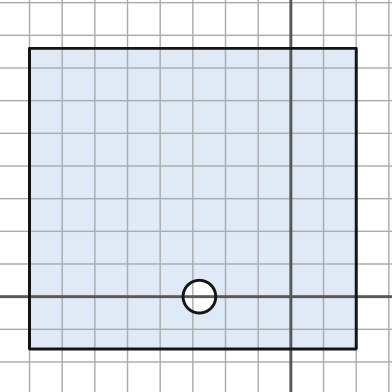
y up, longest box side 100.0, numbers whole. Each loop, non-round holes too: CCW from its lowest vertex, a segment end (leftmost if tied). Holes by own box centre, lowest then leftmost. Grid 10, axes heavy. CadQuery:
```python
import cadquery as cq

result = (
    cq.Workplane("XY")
    .moveTo(-80.0, -16.0)
    .lineTo(20.0, -16.0)
    .lineTo(20.0, 76.0)
    .lineTo(-80.0, 76.0)
    .close()
    .moveTo(-28.0, 0.0)
    .circle(5.0)
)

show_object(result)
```